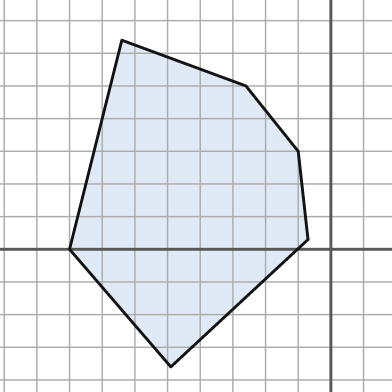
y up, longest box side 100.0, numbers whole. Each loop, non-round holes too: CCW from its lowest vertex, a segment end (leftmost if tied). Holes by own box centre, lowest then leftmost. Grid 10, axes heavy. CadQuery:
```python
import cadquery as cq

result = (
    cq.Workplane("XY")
    .moveTo(-49.0, -36.0)
    .lineTo(-7.0, 3.0)
    .lineTo(-10.0, 30.0)
    .lineTo(-26.0, 50.0)
    .lineTo(-64.0, 64.0)
    .lineTo(-80.0, 0.0)
    .close()
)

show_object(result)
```